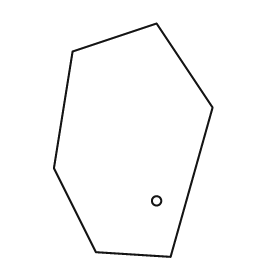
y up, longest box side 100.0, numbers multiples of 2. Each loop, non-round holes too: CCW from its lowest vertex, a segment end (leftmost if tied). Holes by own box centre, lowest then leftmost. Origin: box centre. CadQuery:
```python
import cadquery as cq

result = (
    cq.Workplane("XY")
    .moveTo(16.0, -50.0)
    .lineTo(34.0, 14.0)
    .lineTo(10.0, 50.0)
    .lineTo(-26.0, 38.0)
    .lineTo(-34.0, -12.0)
    .lineTo(-16.0, -48.0)
    .close()
    .moveTo(10.0, -26.0)
    .circle(2.0)
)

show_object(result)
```